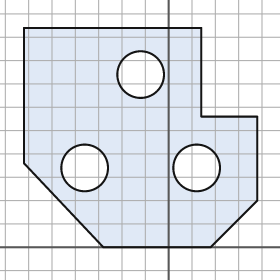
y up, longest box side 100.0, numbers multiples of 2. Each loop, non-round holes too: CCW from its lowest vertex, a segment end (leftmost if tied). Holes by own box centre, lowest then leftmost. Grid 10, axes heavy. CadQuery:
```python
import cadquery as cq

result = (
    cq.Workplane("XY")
    .moveTo(-28.0, 0.0)
    .lineTo(18.0, 0.0)
    .lineTo(38.0, 20.0)
    .lineTo(38.0, 56.0)
    .lineTo(14.0, 56.0)
    .lineTo(14.0, 94.0)
    .lineTo(-62.0, 94.0)
    .lineTo(-62.0, 36.0)
    .close()
    .moveTo(-36.0, 34.0)
    .circle(10.0)
    .moveTo(12.0, 34.0)
    .circle(10.0)
    .moveTo(-12.0, 74.0)
    .circle(10.0)
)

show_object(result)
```